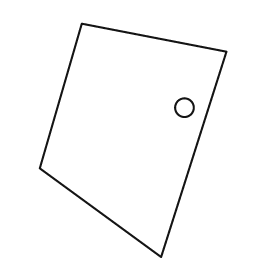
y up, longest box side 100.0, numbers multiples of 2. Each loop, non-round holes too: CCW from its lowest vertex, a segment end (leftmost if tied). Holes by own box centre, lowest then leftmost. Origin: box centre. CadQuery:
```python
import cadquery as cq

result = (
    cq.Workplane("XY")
    .moveTo(12.0, -50.0)
    .lineTo(40.0, 38.0)
    .lineTo(-22.0, 50.0)
    .lineTo(-40.0, -12.0)
    .close()
    .moveTo(22.0, 14.0)
    .circle(4.0)
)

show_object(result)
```